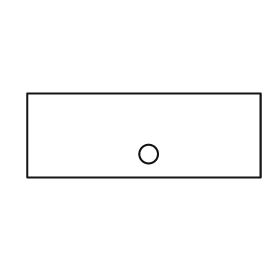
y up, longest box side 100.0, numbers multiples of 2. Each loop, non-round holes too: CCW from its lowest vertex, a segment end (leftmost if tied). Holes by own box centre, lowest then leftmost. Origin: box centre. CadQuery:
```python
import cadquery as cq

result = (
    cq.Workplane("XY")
    .moveTo(-50.0, -18.0)
    .lineTo(50.0, -18.0)
    .lineTo(50.0, 18.0)
    .lineTo(-50.0, 18.0)
    .close()
    .moveTo(2.0, -8.0)
    .circle(4.0)
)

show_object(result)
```